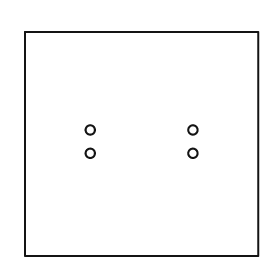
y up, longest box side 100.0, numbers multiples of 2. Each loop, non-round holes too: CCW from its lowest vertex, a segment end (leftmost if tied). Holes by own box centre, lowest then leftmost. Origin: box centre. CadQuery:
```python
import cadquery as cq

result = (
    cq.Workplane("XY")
    .moveTo(-50.0, -48.0)
    .lineTo(50.0, -48.0)
    .lineTo(50.0, 48.0)
    .lineTo(-50.0, 48.0)
    .close()
    .moveTo(-22.0, -4.0)
    .circle(2.0)
    .moveTo(22.0, -4.0)
    .circle(2.0)
    .moveTo(-22.0, 6.0)
    .circle(2.0)
    .moveTo(22.0, 6.0)
    .circle(2.0)
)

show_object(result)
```